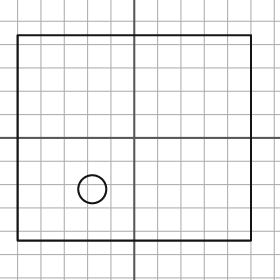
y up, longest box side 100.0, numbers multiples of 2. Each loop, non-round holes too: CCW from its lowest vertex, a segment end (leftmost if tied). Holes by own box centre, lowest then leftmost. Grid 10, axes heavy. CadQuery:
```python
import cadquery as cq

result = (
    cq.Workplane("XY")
    .moveTo(-50.0, -44.0)
    .lineTo(50.0, -44.0)
    .lineTo(50.0, 44.0)
    .lineTo(-50.0, 44.0)
    .close()
    .moveTo(-18.0, -22.0)
    .circle(6.0)
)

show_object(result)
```